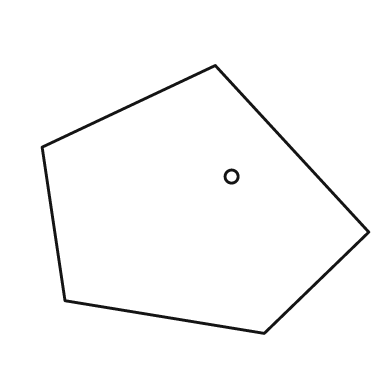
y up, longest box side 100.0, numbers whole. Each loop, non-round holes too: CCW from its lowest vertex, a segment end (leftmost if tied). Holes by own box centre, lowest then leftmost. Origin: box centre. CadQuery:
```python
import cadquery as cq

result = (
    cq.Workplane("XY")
    .moveTo(18.0, -41.0)
    .lineTo(50.0, -10.0)
    .lineTo(3.0, 41.0)
    .lineTo(-50.0, 16.0)
    .lineTo(-43.0, -31.0)
    .close()
    .moveTo(8.0, 7.0)
    .circle(2.0)
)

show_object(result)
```